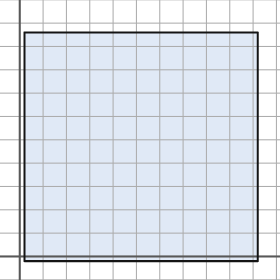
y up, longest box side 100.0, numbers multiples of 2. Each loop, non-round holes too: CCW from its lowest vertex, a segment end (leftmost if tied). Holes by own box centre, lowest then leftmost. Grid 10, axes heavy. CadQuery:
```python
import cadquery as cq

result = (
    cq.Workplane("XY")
    .moveTo(2.0, -2.0)
    .lineTo(102.0, -2.0)
    .lineTo(102.0, 96.0)
    .lineTo(2.0, 96.0)
    .close()
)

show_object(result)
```